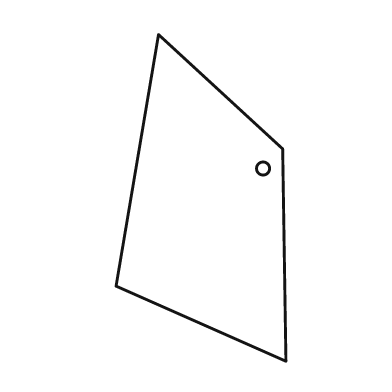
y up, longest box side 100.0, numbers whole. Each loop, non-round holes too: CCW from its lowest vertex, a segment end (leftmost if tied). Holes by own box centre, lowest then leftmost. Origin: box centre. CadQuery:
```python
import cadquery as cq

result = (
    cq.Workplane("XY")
    .moveTo(26.0, -50.0)
    .lineTo(25.0, 15.0)
    .lineTo(-13.0, 50.0)
    .lineTo(-26.0, -27.0)
    .close()
    .moveTo(19.0, 9.0)
    .circle(2.0)
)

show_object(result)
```